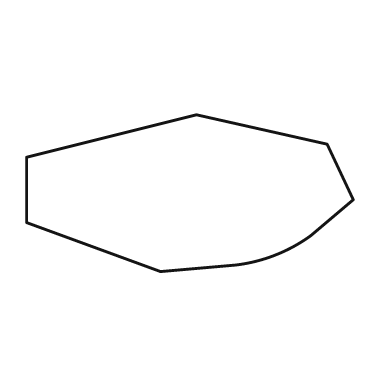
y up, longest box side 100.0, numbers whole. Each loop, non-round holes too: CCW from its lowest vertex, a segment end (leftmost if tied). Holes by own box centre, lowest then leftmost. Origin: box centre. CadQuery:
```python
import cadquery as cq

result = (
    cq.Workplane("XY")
    .moveTo(-9.0, -24.0)
    .lineTo(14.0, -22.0)
    .threePointArc((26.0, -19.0), (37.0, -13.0))
    .lineTo(50.0, -2.0)
    .lineTo(42.0, 15.0)
    .lineTo(2.0, 24.0)
    .lineTo(-50.0, 11.0)
    .lineTo(-50.0, -9.0)
    .close()
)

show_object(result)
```